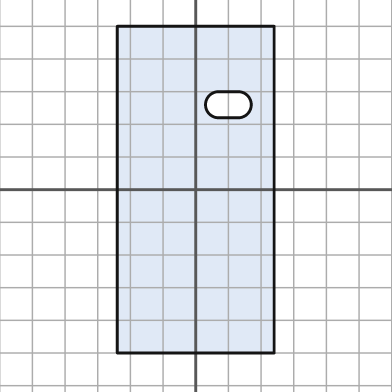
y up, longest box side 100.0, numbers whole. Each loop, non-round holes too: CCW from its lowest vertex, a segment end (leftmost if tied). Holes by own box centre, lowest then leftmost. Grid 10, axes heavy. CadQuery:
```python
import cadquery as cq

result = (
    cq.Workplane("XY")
    .moveTo(-24.0, -50.0)
    .lineTo(24.0, -50.0)
    .lineTo(24.0, 50.0)
    .lineTo(-24.0, 50.0)
    .close()
    .moveTo(7.0, 22.0)
    .lineTo(13.0, 22.0)
    .threePointArc((17.0, 26.0), (13.0, 30.0))
    .lineTo(7.0, 30.0)
    .threePointArc((3.0, 26.0), (7.0, 22.0))
    .close()
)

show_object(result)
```